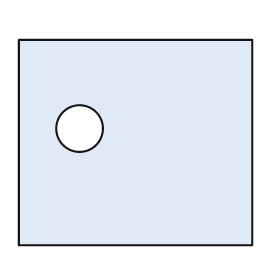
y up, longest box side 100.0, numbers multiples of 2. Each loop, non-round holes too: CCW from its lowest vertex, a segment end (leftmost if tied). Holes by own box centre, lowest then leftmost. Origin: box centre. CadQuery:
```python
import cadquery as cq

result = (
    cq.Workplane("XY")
    .moveTo(-50.0, -44.0)
    .lineTo(50.0, -44.0)
    .lineTo(50.0, 44.0)
    .lineTo(-50.0, 44.0)
    .close()
    .moveTo(-24.0, 6.0)
    .circle(10.0)
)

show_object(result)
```